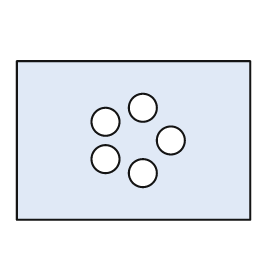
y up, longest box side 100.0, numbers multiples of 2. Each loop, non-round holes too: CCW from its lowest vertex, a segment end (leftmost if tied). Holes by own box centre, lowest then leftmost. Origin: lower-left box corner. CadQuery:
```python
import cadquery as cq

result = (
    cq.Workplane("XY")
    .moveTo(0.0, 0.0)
    .lineTo(100.0, 0.0)
    .lineTo(100.0, 68.0)
    .lineTo(0.0, 68.0)
    .close()
    .moveTo(54.0, 20.0)
    .circle(6.0)
    .moveTo(38.0, 26.0)
    .circle(6.0)
    .moveTo(66.0, 34.0)
    .circle(6.0)
    .moveTo(38.0, 42.0)
    .circle(6.0)
    .moveTo(54.0, 48.0)
    .circle(6.0)
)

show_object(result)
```